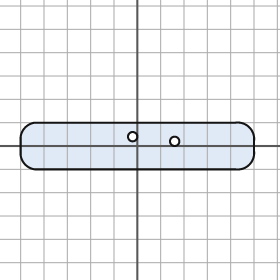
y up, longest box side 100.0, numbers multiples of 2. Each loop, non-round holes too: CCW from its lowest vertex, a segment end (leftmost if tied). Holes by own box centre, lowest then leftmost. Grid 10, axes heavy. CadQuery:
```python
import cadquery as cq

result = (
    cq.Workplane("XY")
    .moveTo(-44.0, -10.0)
    .lineTo(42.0, -10.0)
    .threePointArc((48.0, -8.0), (50.0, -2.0))
    .lineTo(50.0, 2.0)
    .threePointArc((48.0, 8.0), (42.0, 10.0))
    .lineTo(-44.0, 10.0)
    .threePointArc((-48.0, 8.0), (-50.0, 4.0))
    .lineTo(-50.0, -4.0)
    .threePointArc((-48.0, -8.0), (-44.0, -10.0))
    .close()
    .moveTo(16.0, 2.0)
    .circle(2.0)
    .moveTo(-2.0, 4.0)
    .circle(2.0)
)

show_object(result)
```